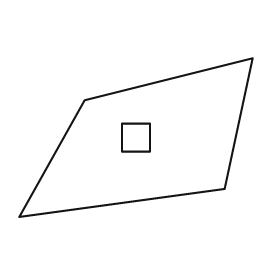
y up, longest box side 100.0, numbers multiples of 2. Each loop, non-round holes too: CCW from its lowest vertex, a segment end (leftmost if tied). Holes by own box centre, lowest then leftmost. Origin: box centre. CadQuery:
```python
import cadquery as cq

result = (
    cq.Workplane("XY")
    .moveTo(-50.0, -34.0)
    .lineTo(38.0, -22.0)
    .lineTo(50.0, 34.0)
    .lineTo(-22.0, 16.0)
    .close()
    .moveTo(-6.0, -6.0)
    .lineTo(6.0, -6.0)
    .lineTo(6.0, 6.0)
    .lineTo(-6.0, 6.0)
    .close()
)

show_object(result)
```